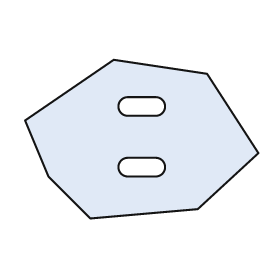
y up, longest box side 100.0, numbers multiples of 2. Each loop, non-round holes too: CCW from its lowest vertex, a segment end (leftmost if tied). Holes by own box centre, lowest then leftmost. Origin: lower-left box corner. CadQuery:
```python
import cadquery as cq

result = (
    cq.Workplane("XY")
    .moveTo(28.0, 0.0)
    .lineTo(74.0, 4.0)
    .lineTo(100.0, 28.0)
    .lineTo(78.0, 62.0)
    .lineTo(38.0, 68.0)
    .lineTo(0.0, 42.0)
    .lineTo(10.0, 18.0)
    .close()
    .moveTo(44.0, 18.0)
    .lineTo(56.0, 18.0)
    .threePointArc((60.0, 22.0), (56.0, 26.0))
    .lineTo(44.0, 26.0)
    .threePointArc((40.0, 22.0), (44.0, 18.0))
    .close()
    .moveTo(44.0, 44.0)
    .lineTo(56.0, 44.0)
    .threePointArc((60.0, 48.0), (56.0, 52.0))
    .lineTo(44.0, 52.0)
    .threePointArc((40.0, 48.0), (44.0, 44.0))
    .close()
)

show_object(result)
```